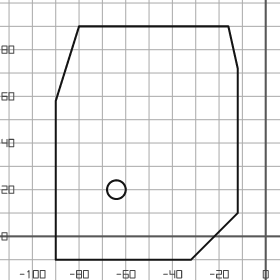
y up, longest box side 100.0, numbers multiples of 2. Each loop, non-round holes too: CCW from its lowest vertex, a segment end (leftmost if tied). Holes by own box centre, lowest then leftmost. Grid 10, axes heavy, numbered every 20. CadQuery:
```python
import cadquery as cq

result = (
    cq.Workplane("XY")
    .moveTo(-90.0, -10.0)
    .lineTo(-32.0, -10.0)
    .lineTo(-12.0, 10.0)
    .lineTo(-12.0, 72.0)
    .lineTo(-16.0, 90.0)
    .lineTo(-80.0, 90.0)
    .lineTo(-90.0, 58.0)
    .close()
    .moveTo(-64.0, 20.0)
    .circle(4.0)
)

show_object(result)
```